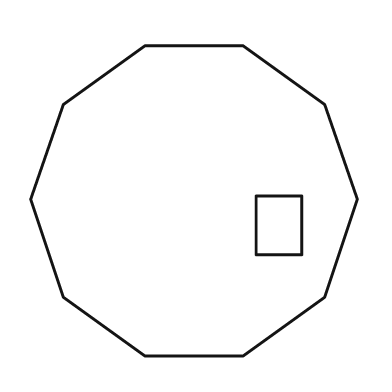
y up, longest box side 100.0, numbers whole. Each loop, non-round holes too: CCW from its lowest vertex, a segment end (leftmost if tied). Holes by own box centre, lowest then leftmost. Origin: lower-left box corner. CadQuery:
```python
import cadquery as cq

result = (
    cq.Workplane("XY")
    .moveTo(35.0, 0.0)
    .lineTo(65.0, 0.0)
    .lineTo(90.0, 18.0)
    .lineTo(100.0, 48.0)
    .lineTo(90.0, 77.0)
    .lineTo(65.0, 95.0)
    .lineTo(35.0, 95.0)
    .lineTo(10.0, 77.0)
    .lineTo(0.0, 48.0)
    .lineTo(10.0, 18.0)
    .close()
    .moveTo(69.0, 31.0)
    .lineTo(83.0, 31.0)
    .lineTo(83.0, 49.0)
    .lineTo(69.0, 49.0)
    .close()
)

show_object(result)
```